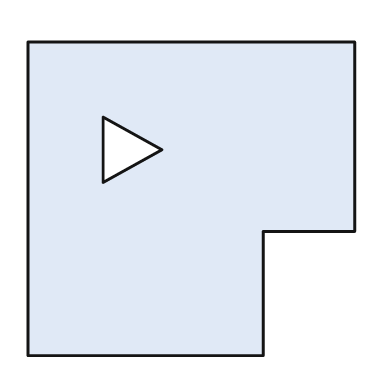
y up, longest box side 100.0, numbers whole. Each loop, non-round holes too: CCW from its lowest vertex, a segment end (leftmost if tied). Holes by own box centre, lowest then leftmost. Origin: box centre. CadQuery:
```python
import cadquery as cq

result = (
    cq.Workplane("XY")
    .moveTo(-50.0, -48.0)
    .lineTo(22.0, -48.0)
    .lineTo(22.0, -10.0)
    .lineTo(50.0, -10.0)
    .lineTo(50.0, 48.0)
    .lineTo(-50.0, 48.0)
    .close()
    .moveTo(-27.0, 5.0)
    .lineTo(-9.0, 15.0)
    .lineTo(-27.0, 25.0)
    .close()
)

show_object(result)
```